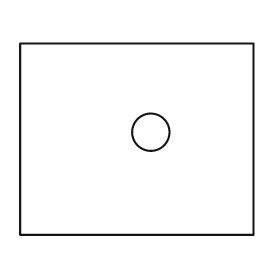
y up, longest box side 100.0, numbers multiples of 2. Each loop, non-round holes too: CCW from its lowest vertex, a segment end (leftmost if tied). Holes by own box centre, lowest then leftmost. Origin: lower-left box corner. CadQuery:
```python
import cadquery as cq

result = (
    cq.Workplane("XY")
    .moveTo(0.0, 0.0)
    .lineTo(100.0, 0.0)
    .lineTo(100.0, 82.0)
    .lineTo(0.0, 82.0)
    .close()
    .moveTo(56.0, 44.0)
    .circle(8.0)
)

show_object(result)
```